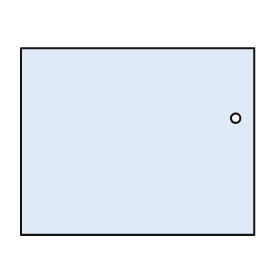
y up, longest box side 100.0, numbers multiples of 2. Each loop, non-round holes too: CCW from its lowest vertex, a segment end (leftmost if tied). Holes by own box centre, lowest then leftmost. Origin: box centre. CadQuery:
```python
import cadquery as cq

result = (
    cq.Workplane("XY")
    .moveTo(-50.0, -40.0)
    .lineTo(50.0, -40.0)
    .lineTo(50.0, 40.0)
    .lineTo(-50.0, 40.0)
    .close()
    .moveTo(42.0, 10.0)
    .circle(2.0)
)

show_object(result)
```